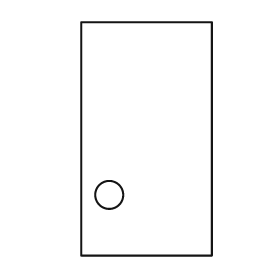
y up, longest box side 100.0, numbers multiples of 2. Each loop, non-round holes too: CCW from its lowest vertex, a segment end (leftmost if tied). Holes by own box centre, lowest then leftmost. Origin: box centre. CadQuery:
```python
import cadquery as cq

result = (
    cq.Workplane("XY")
    .moveTo(-28.0, -50.0)
    .lineTo(28.0, -50.0)
    .lineTo(28.0, 50.0)
    .lineTo(-28.0, 50.0)
    .close()
    .moveTo(-16.0, -24.0)
    .circle(6.0)
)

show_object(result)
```